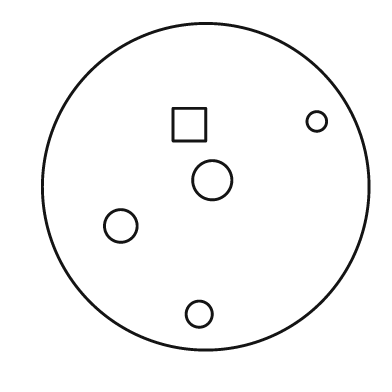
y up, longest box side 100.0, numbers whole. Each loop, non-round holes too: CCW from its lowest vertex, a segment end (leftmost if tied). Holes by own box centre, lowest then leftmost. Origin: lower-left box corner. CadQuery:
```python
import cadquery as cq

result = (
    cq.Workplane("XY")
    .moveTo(50.0, 50.0)
    .circle(50.0)
    .moveTo(48.0, 11.0)
    .circle(4.0)
    .moveTo(24.0, 38.0)
    .circle(5.0)
    .moveTo(52.0, 52.0)
    .circle(6.0)
    .moveTo(40.0, 64.0)
    .lineTo(50.0, 64.0)
    .lineTo(50.0, 74.0)
    .lineTo(40.0, 74.0)
    .close()
    .moveTo(84.0, 70.0)
    .circle(3.0)
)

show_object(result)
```